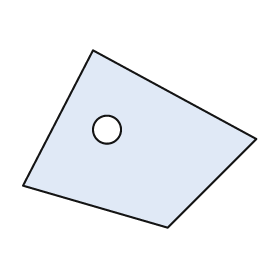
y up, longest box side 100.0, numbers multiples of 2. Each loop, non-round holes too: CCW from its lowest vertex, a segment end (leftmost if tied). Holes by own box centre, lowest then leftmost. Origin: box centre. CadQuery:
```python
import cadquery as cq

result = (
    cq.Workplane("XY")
    .moveTo(12.0, -38.0)
    .lineTo(50.0, 0.0)
    .lineTo(-20.0, 38.0)
    .lineTo(-50.0, -20.0)
    .close()
    .moveTo(-14.0, 4.0)
    .circle(6.0)
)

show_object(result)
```